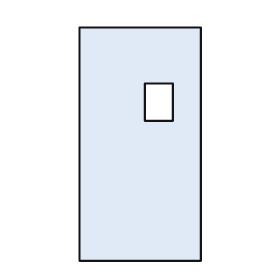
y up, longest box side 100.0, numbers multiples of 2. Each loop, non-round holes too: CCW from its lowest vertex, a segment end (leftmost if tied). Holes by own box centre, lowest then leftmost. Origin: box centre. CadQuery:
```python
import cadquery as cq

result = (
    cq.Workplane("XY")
    .moveTo(-26.0, -50.0)
    .lineTo(26.0, -50.0)
    .lineTo(26.0, 50.0)
    .lineTo(-26.0, 50.0)
    .close()
    .moveTo(2.0, 10.0)
    .lineTo(14.0, 10.0)
    .lineTo(14.0, 26.0)
    .lineTo(2.0, 26.0)
    .close()
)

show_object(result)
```